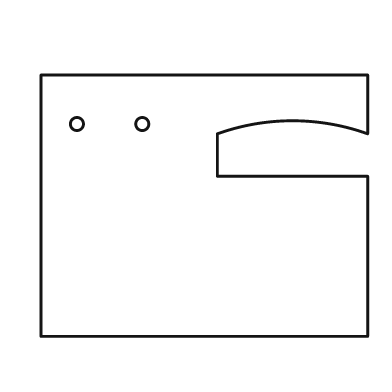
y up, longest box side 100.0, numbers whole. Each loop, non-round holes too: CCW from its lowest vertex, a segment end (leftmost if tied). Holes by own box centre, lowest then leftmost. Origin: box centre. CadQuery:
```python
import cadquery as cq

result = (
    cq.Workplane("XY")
    .moveTo(-50.0, -40.0)
    .lineTo(50.0, -40.0)
    .lineTo(50.0, 9.0)
    .lineTo(4.0, 9.0)
    .lineTo(4.0, 22.0)
    .threePointArc((27.0, 26.0), (50.0, 22.0))
    .lineTo(50.0, 40.0)
    .lineTo(-50.0, 40.0)
    .close()
    .moveTo(-39.0, 25.0)
    .circle(2.0)
    .moveTo(-19.0, 25.0)
    .circle(2.0)
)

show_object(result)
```